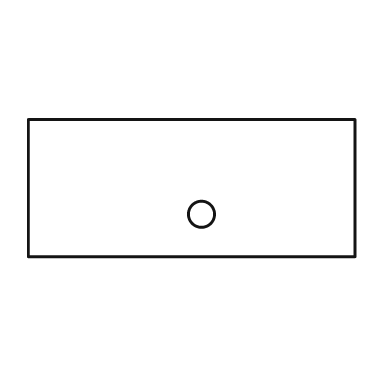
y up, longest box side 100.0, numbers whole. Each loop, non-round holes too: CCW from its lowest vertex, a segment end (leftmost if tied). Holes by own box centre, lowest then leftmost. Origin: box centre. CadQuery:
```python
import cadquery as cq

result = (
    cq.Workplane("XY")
    .moveTo(-50.0, -21.0)
    .lineTo(50.0, -21.0)
    .lineTo(50.0, 21.0)
    .lineTo(-50.0, 21.0)
    .close()
    .moveTo(3.0, -8.0)
    .circle(4.0)
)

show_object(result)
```